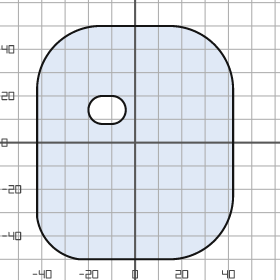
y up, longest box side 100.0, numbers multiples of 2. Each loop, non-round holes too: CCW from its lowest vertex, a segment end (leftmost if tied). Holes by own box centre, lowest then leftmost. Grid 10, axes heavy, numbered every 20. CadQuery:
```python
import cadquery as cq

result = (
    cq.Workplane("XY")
    .moveTo(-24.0, -50.0)
    .lineTo(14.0, -50.0)
    .threePointArc((34.0, -42.0), (42.0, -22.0))
    .lineTo(42.0, 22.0)
    .threePointArc((34.0, 42.0), (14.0, 50.0))
    .lineTo(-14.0, 50.0)
    .threePointArc((-34.0, 42.0), (-42.0, 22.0))
    .lineTo(-42.0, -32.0)
    .threePointArc((-36.0, -44.0), (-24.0, -50.0))
    .close()
    .moveTo(-14.0, 8.0)
    .lineTo(-10.0, 8.0)
    .threePointArc((-4.0, 14.0), (-10.0, 20.0))
    .lineTo(-14.0, 20.0)
    .threePointArc((-20.0, 14.0), (-14.0, 8.0))
    .close()
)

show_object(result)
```